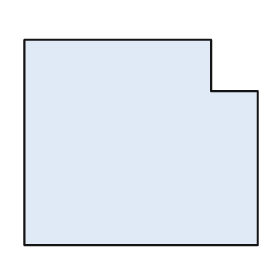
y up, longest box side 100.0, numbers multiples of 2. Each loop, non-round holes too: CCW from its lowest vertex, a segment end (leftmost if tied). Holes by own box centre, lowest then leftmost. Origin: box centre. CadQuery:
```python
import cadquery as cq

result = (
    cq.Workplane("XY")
    .moveTo(-50.0, -44.0)
    .lineTo(50.0, -44.0)
    .lineTo(50.0, 22.0)
    .lineTo(30.0, 22.0)
    .lineTo(30.0, 44.0)
    .lineTo(-50.0, 44.0)
    .close()
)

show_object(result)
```